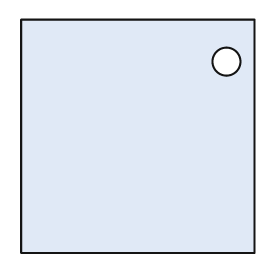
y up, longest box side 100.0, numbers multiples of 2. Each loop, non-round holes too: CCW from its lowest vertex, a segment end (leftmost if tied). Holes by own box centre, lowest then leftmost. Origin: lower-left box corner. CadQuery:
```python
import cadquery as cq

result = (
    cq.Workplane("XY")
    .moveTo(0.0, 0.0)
    .lineTo(100.0, 0.0)
    .lineTo(100.0, 100.0)
    .lineTo(0.0, 100.0)
    .close()
    .moveTo(88.0, 82.0)
    .circle(6.0)
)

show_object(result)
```